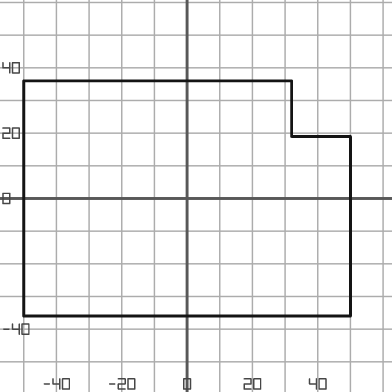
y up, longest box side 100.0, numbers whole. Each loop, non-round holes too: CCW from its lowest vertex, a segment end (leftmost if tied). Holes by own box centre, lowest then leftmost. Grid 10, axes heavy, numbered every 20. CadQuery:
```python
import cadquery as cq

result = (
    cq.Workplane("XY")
    .moveTo(-50.0, -36.0)
    .lineTo(50.0, -36.0)
    .lineTo(50.0, 19.0)
    .lineTo(32.0, 19.0)
    .lineTo(32.0, 36.0)
    .lineTo(-50.0, 36.0)
    .close()
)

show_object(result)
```